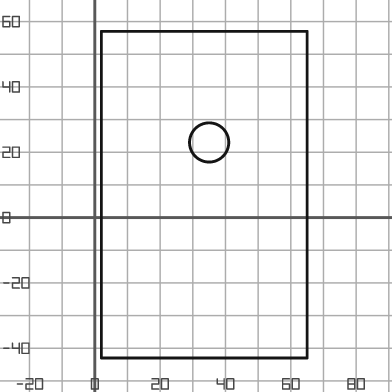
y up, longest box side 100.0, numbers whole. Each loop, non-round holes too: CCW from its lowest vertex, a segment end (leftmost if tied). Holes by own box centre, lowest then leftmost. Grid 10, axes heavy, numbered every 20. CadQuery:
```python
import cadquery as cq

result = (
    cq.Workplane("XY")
    .moveTo(2.0, -43.0)
    .lineTo(65.0, -43.0)
    .lineTo(65.0, 57.0)
    .lineTo(2.0, 57.0)
    .close()
    .moveTo(35.0, 23.0)
    .circle(6.0)
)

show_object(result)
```